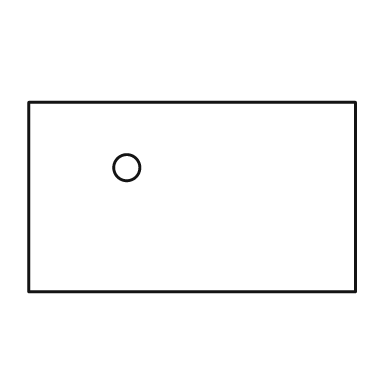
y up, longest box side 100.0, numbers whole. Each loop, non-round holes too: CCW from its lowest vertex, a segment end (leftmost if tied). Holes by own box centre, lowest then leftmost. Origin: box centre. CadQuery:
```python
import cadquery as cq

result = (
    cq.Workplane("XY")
    .moveTo(-50.0, -29.0)
    .lineTo(50.0, -29.0)
    .lineTo(50.0, 29.0)
    .lineTo(-50.0, 29.0)
    .close()
    .moveTo(-20.0, 9.0)
    .circle(4.0)
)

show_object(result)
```